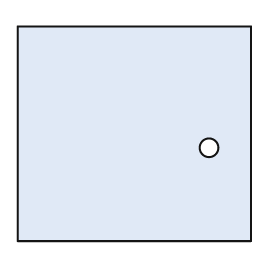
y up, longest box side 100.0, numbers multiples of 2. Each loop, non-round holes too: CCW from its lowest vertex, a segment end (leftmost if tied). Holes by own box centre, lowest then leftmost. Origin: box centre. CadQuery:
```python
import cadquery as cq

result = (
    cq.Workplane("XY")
    .moveTo(-50.0, -46.0)
    .lineTo(50.0, -46.0)
    .lineTo(50.0, 46.0)
    .lineTo(-50.0, 46.0)
    .close()
    .moveTo(32.0, -6.0)
    .circle(4.0)
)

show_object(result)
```